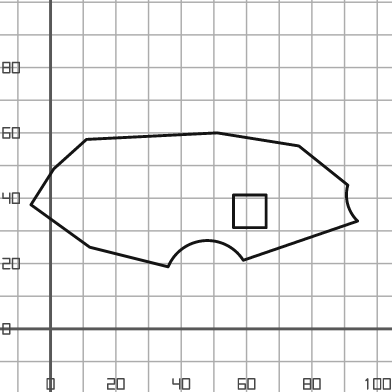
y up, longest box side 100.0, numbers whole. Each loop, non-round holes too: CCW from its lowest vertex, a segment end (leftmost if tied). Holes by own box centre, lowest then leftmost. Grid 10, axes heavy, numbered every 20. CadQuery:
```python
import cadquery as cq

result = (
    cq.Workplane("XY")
    .moveTo(36.0, 19.0)
    .threePointArc((47.0, 27.0), (59.0, 21.0))
    .lineTo(94.0, 33.0)
    .threePointArc((91.0, 38.0), (91.0, 44.0))
    .lineTo(76.0, 56.0)
    .lineTo(51.0, 60.0)
    .lineTo(11.0, 58.0)
    .lineTo(1.0, 49.0)
    .lineTo(-6.0, 38.0)
    .lineTo(12.0, 25.0)
    .close()
    .moveTo(56.0, 31.0)
    .lineTo(66.0, 31.0)
    .lineTo(66.0, 41.0)
    .lineTo(56.0, 41.0)
    .close()
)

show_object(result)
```